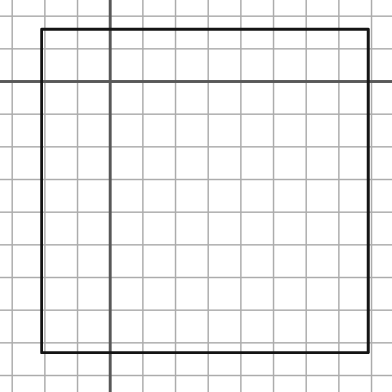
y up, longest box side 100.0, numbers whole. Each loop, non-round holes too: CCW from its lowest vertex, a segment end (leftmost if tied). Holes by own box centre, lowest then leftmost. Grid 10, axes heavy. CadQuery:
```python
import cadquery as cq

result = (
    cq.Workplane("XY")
    .moveTo(-21.0, -83.0)
    .lineTo(79.0, -83.0)
    .lineTo(79.0, 16.0)
    .lineTo(-21.0, 16.0)
    .close()
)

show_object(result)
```